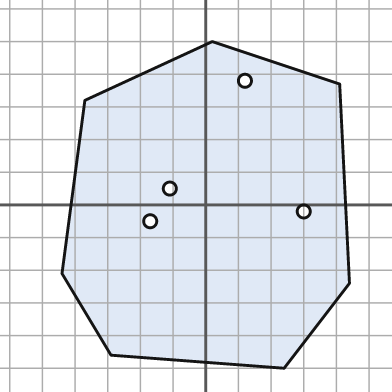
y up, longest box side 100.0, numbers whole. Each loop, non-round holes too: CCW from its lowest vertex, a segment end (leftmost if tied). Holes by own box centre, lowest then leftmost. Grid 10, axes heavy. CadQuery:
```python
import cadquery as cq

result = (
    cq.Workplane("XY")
    .moveTo(24.0, -50.0)
    .lineTo(44.0, -24.0)
    .lineTo(41.0, 37.0)
    .lineTo(2.0, 50.0)
    .lineTo(-37.0, 32.0)
    .lineTo(-44.0, -21.0)
    .lineTo(-29.0, -46.0)
    .close()
    .moveTo(-17.0, -5.0)
    .circle(2.0)
    .moveTo(30.0, -2.0)
    .circle(2.0)
    .moveTo(-11.0, 5.0)
    .circle(2.0)
    .moveTo(12.0, 38.0)
    .circle(2.0)
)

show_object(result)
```